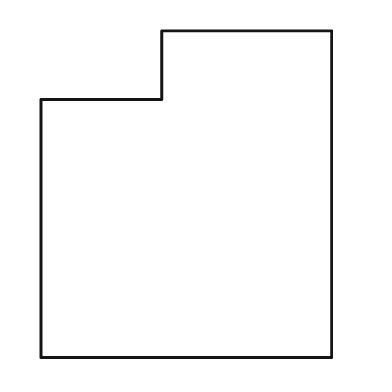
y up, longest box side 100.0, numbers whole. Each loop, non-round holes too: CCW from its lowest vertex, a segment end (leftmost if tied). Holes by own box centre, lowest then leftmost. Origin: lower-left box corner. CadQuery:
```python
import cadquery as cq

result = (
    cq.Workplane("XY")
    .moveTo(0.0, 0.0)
    .lineTo(89.0, 0.0)
    .lineTo(89.0, 100.0)
    .lineTo(37.0, 100.0)
    .lineTo(37.0, 79.0)
    .lineTo(0.0, 79.0)
    .close()
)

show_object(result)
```